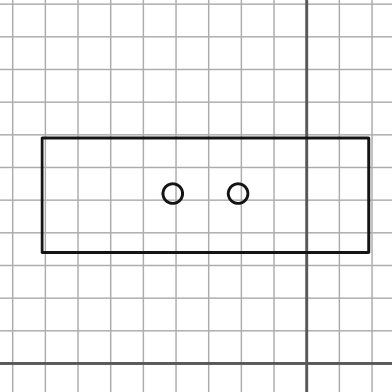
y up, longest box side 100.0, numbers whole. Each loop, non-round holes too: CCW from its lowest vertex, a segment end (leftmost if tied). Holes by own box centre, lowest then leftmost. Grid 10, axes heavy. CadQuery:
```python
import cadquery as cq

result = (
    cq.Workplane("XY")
    .moveTo(-81.0, 34.0)
    .lineTo(19.0, 34.0)
    .lineTo(19.0, 69.0)
    .lineTo(-81.0, 69.0)
    .close()
    .moveTo(-41.0, 52.0)
    .circle(3.0)
    .moveTo(-21.0, 52.0)
    .circle(3.0)
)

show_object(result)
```